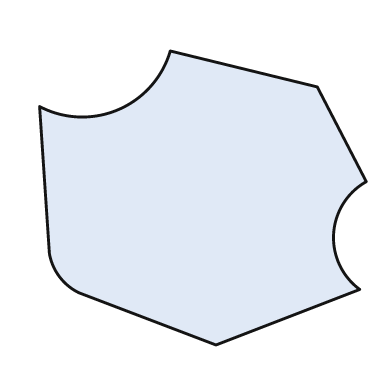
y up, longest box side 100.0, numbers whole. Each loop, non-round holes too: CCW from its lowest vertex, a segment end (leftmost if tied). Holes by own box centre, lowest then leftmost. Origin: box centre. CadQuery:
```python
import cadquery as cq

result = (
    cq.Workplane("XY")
    .moveTo(4.0, -45.0)
    .lineTo(48.0, -28.0)
    .threePointArc((40.0, -11.0), (50.0, 5.0))
    .lineTo(35.0, 34.0)
    .lineTo(-10.0, 45.0)
    .threePointArc((-26.0, 27.0), (-50.0, 28.0))
    .lineTo(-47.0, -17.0)
    .threePointArc((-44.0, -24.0), (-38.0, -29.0))
    .close()
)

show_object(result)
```